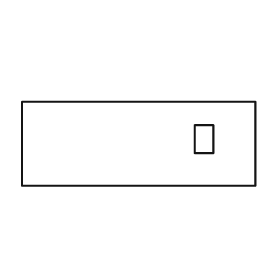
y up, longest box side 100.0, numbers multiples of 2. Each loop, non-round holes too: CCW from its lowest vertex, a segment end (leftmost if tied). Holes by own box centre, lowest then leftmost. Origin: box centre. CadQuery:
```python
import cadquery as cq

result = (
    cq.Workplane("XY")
    .moveTo(-50.0, -18.0)
    .lineTo(50.0, -18.0)
    .lineTo(50.0, 18.0)
    .lineTo(-50.0, 18.0)
    .close()
    .moveTo(24.0, -4.0)
    .lineTo(32.0, -4.0)
    .lineTo(32.0, 8.0)
    .lineTo(24.0, 8.0)
    .close()
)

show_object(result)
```